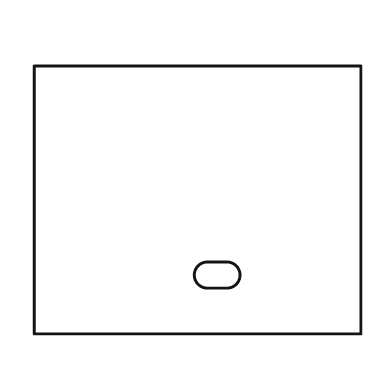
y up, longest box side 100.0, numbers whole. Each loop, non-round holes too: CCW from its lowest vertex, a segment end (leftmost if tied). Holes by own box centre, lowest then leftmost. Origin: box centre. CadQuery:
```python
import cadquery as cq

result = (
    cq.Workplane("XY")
    .moveTo(-50.0, -41.0)
    .lineTo(50.0, -41.0)
    .lineTo(50.0, 41.0)
    .lineTo(-50.0, 41.0)
    .close()
    .moveTo(3.0, -27.0)
    .lineTo(9.0, -27.0)
    .threePointArc((13.0, -23.0), (9.0, -19.0))
    .lineTo(3.0, -19.0)
    .threePointArc((-1.0, -23.0), (3.0, -27.0))
    .close()
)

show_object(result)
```